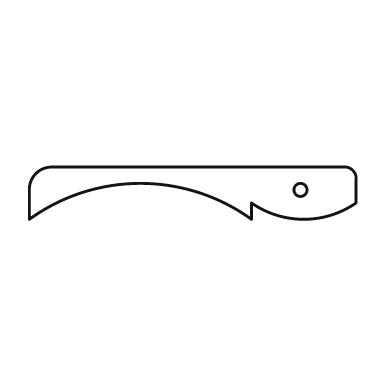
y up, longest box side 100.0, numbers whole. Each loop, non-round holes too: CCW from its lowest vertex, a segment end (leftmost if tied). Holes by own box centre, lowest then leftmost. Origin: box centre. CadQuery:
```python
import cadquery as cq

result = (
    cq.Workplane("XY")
    .moveTo(-50.0, -8.0)
    .threePointArc((-16.0, 3.0), (18.0, -8.0))
    .lineTo(18.0, -3.0)
    .threePointArc((34.0, -8.0), (50.0, -3.0))
    .lineTo(50.0, 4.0)
    .threePointArc((49.0, 7.0), (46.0, 8.0))
    .lineTo(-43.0, 8.0)
    .threePointArc((-48.0, 6.0), (-50.0, 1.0))
    .close()
    .moveTo(33.0, 1.0)
    .circle(2.0)
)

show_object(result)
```